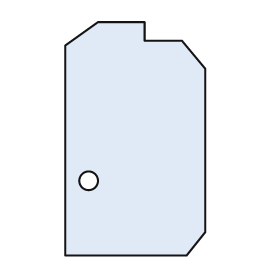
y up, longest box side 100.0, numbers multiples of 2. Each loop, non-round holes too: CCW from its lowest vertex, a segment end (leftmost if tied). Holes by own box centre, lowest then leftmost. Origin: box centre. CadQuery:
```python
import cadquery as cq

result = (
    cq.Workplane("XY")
    .moveTo(-30.0, -50.0)
    .lineTo(22.0, -50.0)
    .lineTo(30.0, -40.0)
    .lineTo(30.0, 30.0)
    .lineTo(20.0, 42.0)
    .lineTo(4.0, 42.0)
    .lineTo(4.0, 50.0)
    .lineTo(-16.0, 50.0)
    .lineTo(-30.0, 40.0)
    .close()
    .moveTo(-20.0, -18.0)
    .circle(4.0)
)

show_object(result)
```